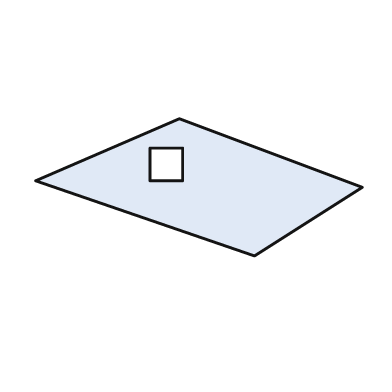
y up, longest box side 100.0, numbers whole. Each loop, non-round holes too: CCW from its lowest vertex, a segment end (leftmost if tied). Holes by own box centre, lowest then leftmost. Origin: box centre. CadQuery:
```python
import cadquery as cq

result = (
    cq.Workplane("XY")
    .moveTo(17.0, -21.0)
    .lineTo(50.0, 0.0)
    .lineTo(-6.0, 21.0)
    .lineTo(-50.0, 2.0)
    .close()
    .moveTo(-15.0, 2.0)
    .lineTo(-5.0, 2.0)
    .lineTo(-5.0, 12.0)
    .lineTo(-15.0, 12.0)
    .close()
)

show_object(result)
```